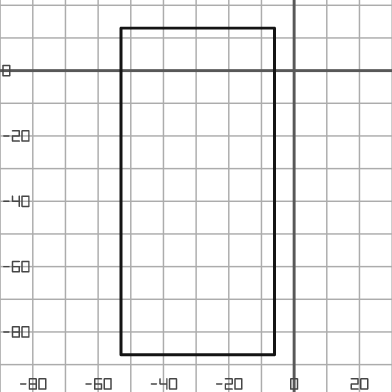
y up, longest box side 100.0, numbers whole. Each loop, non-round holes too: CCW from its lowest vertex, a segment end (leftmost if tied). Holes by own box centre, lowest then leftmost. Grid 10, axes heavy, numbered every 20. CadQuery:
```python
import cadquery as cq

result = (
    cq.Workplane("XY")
    .moveTo(-53.0, -87.0)
    .lineTo(-6.0, -87.0)
    .lineTo(-6.0, 13.0)
    .lineTo(-53.0, 13.0)
    .close()
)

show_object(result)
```